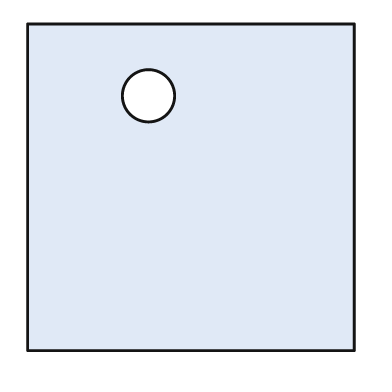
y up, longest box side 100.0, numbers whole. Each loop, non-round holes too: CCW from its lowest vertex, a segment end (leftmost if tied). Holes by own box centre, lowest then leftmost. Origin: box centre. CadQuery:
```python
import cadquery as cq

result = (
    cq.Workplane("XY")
    .moveTo(-50.0, -50.0)
    .lineTo(50.0, -50.0)
    .lineTo(50.0, 50.0)
    .lineTo(-50.0, 50.0)
    .close()
    .moveTo(-13.0, 28.0)
    .circle(8.0)
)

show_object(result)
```